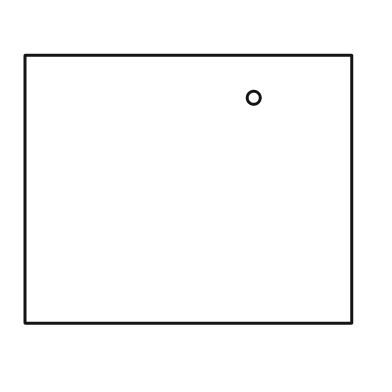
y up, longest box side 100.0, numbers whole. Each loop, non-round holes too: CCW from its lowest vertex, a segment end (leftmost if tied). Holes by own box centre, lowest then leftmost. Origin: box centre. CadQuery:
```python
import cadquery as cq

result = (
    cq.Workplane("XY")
    .moveTo(-50.0, -41.0)
    .lineTo(50.0, -41.0)
    .lineTo(50.0, 41.0)
    .lineTo(-50.0, 41.0)
    .close()
    .moveTo(20.0, 28.0)
    .circle(2.0)
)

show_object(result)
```